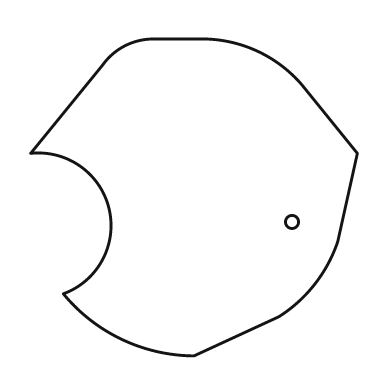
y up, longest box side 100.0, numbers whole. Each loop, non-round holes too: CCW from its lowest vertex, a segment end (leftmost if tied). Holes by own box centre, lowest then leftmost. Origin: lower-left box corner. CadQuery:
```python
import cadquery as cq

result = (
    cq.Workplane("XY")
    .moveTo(50.0, 0.0)
    .lineTo(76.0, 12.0)
    .threePointArc((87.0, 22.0), (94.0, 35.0))
    .lineTo(100.0, 62.0)
    .lineTo(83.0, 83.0)
    .threePointArc((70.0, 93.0), (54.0, 97.0))
    .lineTo(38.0, 97.0)
    .threePointArc((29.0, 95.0), (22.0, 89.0))
    .lineTo(0.0, 62.0)
    .threePointArc((24.0, 45.0), (10.0, 19.0))
    .threePointArc((28.0, 5.0), (50.0, 0.0))
    .close()
    .moveTo(80.0, 41.0)
    .circle(2.0)
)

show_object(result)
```